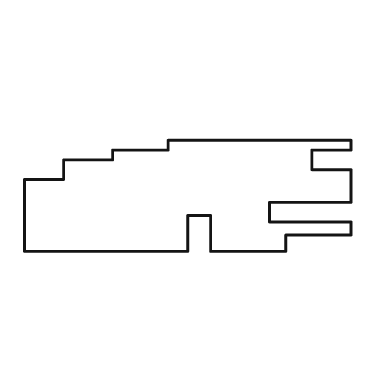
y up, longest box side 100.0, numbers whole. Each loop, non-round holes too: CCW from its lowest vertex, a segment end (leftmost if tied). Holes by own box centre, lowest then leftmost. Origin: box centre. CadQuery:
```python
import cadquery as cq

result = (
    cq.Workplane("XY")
    .moveTo(-50.0, -17.0)
    .lineTo(0.0, -17.0)
    .lineTo(0.0, -6.0)
    .lineTo(7.0, -6.0)
    .lineTo(7.0, -17.0)
    .lineTo(30.0, -17.0)
    .lineTo(30.0, -12.0)
    .lineTo(50.0, -12.0)
    .lineTo(50.0, -8.0)
    .lineTo(25.0, -8.0)
    .lineTo(25.0, -2.0)
    .lineTo(50.0, -2.0)
    .lineTo(50.0, 8.0)
    .lineTo(38.0, 8.0)
    .lineTo(38.0, 14.0)
    .lineTo(50.0, 14.0)
    .lineTo(50.0, 17.0)
    .lineTo(-6.0, 17.0)
    .lineTo(-6.0, 14.0)
    .lineTo(-23.0, 14.0)
    .lineTo(-23.0, 11.0)
    .lineTo(-38.0, 11.0)
    .lineTo(-38.0, 5.0)
    .lineTo(-50.0, 5.0)
    .close()
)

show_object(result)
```